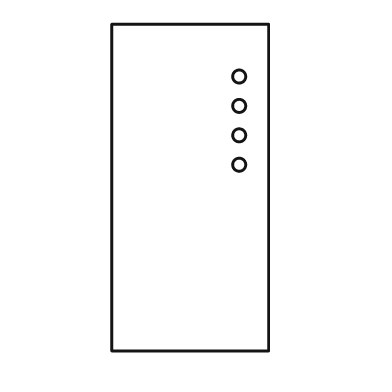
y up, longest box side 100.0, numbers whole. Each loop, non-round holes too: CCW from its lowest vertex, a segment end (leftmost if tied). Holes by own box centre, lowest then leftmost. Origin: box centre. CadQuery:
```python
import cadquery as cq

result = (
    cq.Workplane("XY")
    .moveTo(-24.0, -50.0)
    .lineTo(24.0, -50.0)
    .lineTo(24.0, 50.0)
    .lineTo(-24.0, 50.0)
    .close()
    .moveTo(15.0, 7.0)
    .circle(2.0)
    .moveTo(15.0, 16.0)
    .circle(2.0)
    .moveTo(15.0, 25.0)
    .circle(2.0)
    .moveTo(15.0, 34.0)
    .circle(2.0)
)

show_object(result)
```